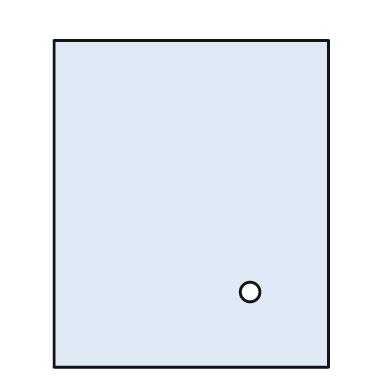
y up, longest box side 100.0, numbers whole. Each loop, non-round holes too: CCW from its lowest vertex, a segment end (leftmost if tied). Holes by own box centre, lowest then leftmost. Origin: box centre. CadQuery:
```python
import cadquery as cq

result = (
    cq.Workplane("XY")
    .moveTo(-42.0, -50.0)
    .lineTo(42.0, -50.0)
    .lineTo(42.0, 50.0)
    .lineTo(-42.0, 50.0)
    .close()
    .moveTo(18.0, -27.0)
    .circle(3.0)
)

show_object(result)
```